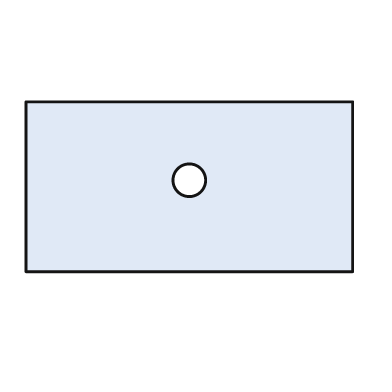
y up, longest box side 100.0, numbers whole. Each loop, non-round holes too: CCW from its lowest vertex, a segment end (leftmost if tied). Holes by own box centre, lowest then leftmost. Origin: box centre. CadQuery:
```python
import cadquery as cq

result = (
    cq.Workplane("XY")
    .moveTo(-50.0, -26.0)
    .lineTo(50.0, -26.0)
    .lineTo(50.0, 26.0)
    .lineTo(-50.0, 26.0)
    .close()
    .moveTo(0.0, 2.0)
    .circle(5.0)
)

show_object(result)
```